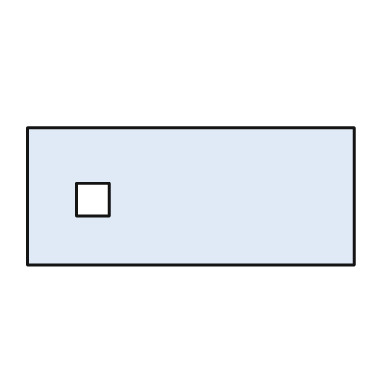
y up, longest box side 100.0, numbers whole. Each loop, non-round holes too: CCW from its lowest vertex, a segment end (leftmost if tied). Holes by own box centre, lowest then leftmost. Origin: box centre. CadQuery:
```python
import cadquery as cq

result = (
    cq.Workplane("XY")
    .moveTo(-50.0, -21.0)
    .lineTo(50.0, -21.0)
    .lineTo(50.0, 21.0)
    .lineTo(-50.0, 21.0)
    .close()
    .moveTo(-35.0, -6.0)
    .lineTo(-25.0, -6.0)
    .lineTo(-25.0, 4.0)
    .lineTo(-35.0, 4.0)
    .close()
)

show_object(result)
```